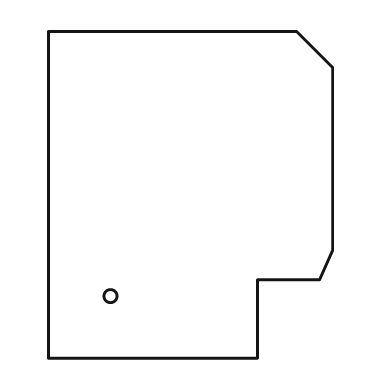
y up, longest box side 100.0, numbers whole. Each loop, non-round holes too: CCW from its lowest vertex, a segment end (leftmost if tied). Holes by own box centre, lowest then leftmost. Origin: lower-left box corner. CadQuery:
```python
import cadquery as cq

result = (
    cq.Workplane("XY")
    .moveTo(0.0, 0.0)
    .lineTo(64.0, 0.0)
    .lineTo(64.0, 24.0)
    .lineTo(83.0, 24.0)
    .lineTo(87.0, 33.0)
    .lineTo(87.0, 89.0)
    .lineTo(76.0, 100.0)
    .lineTo(0.0, 100.0)
    .close()
    .moveTo(19.0, 19.0)
    .circle(2.0)
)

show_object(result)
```